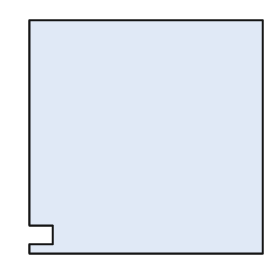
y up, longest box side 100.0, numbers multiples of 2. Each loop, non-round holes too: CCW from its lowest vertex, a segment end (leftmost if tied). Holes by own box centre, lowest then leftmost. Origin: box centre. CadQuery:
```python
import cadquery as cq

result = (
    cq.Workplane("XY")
    .moveTo(-50.0, -50.0)
    .lineTo(50.0, -50.0)
    .lineTo(50.0, 50.0)
    .lineTo(-50.0, 50.0)
    .lineTo(-50.0, -38.0)
    .lineTo(-40.0, -38.0)
    .lineTo(-40.0, -46.0)
    .lineTo(-50.0, -46.0)
    .close()
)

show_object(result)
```